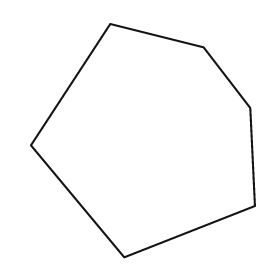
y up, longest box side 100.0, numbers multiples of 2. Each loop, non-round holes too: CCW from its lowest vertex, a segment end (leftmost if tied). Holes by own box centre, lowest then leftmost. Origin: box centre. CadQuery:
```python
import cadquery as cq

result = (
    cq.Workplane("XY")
    .moveTo(-8.0, -50.0)
    .lineTo(48.0, -28.0)
    .lineTo(46.0, 14.0)
    .lineTo(26.0, 40.0)
    .lineTo(-14.0, 50.0)
    .lineTo(-48.0, -2.0)
    .close()
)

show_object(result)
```